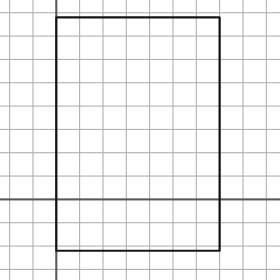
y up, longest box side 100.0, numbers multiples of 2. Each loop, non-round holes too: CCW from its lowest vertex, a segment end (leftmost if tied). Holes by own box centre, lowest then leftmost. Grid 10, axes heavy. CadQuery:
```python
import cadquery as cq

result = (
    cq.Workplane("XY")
    .moveTo(0.0, -22.0)
    .lineTo(70.0, -22.0)
    .lineTo(70.0, 78.0)
    .lineTo(0.0, 78.0)
    .close()
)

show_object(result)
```